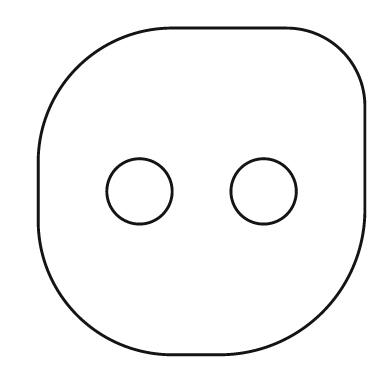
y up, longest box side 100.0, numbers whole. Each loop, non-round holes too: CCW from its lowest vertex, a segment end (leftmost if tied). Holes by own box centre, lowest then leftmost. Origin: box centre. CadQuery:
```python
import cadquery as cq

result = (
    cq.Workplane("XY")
    .moveTo(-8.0, -50.0)
    .lineTo(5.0, -50.0)
    .threePointArc((37.0, -37.0), (50.0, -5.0))
    .lineTo(50.0, 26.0)
    .threePointArc((43.0, 43.0), (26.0, 50.0))
    .lineTo(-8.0, 50.0)
    .threePointArc((-38.0, 38.0), (-50.0, 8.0))
    .lineTo(-50.0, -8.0)
    .threePointArc((-38.0, -38.0), (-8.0, -50.0))
    .close()
    .moveTo(-19.0, 0.0)
    .circle(10.0)
    .moveTo(19.0, 0.0)
    .circle(10.0)
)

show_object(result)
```